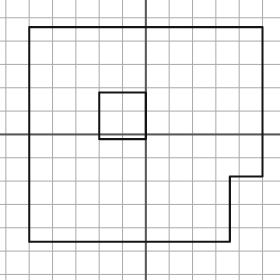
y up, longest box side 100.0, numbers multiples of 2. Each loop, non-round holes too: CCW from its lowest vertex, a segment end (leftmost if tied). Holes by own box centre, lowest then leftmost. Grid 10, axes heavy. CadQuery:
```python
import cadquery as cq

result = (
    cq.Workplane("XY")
    .moveTo(-50.0, -46.0)
    .lineTo(36.0, -46.0)
    .lineTo(36.0, -18.0)
    .lineTo(50.0, -18.0)
    .lineTo(50.0, 46.0)
    .lineTo(-50.0, 46.0)
    .close()
    .moveTo(-20.0, -2.0)
    .lineTo(0.0, -2.0)
    .lineTo(0.0, 18.0)
    .lineTo(-20.0, 18.0)
    .close()
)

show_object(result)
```